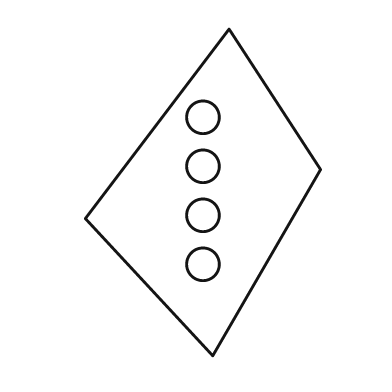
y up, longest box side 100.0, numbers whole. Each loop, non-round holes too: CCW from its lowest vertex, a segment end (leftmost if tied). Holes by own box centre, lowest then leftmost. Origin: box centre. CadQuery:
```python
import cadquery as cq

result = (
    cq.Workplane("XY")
    .moveTo(3.0, -50.0)
    .lineTo(36.0, 7.0)
    .lineTo(8.0, 50.0)
    .lineTo(-36.0, -8.0)
    .close()
    .moveTo(0.0, -22.0)
    .circle(5.0)
    .moveTo(0.0, -7.0)
    .circle(5.0)
    .moveTo(0.0, 8.0)
    .circle(5.0)
    .moveTo(0.0, 23.0)
    .circle(5.0)
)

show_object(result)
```